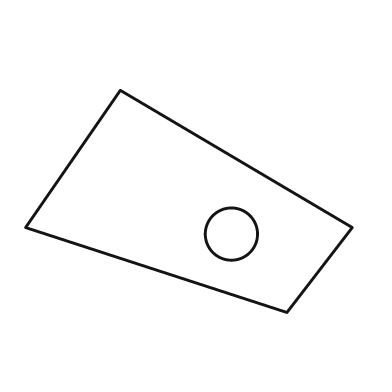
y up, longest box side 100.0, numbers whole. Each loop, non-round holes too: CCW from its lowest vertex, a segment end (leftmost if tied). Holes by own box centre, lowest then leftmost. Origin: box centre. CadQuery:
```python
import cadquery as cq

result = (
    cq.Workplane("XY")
    .moveTo(30.0, -34.0)
    .lineTo(50.0, -8.0)
    .lineTo(-21.0, 34.0)
    .lineTo(-50.0, -8.0)
    .close()
    .moveTo(13.0, -10.0)
    .circle(8.0)
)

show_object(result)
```